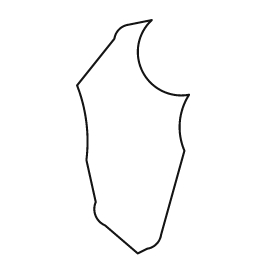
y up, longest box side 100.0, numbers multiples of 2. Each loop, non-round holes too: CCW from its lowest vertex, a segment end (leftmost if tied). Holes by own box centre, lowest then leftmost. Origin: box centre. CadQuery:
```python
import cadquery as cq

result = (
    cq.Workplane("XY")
    .moveTo(2.0, -50.0)
    .lineTo(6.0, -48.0)
    .threePointArc((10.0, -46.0), (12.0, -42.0))
    .lineTo(22.0, -6.0)
    .threePointArc((20.0, 6.0), (24.0, 18.0))
    .threePointArc((4.0, 28.0), (8.0, 50.0))
    .lineTo(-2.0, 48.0)
    .threePointArc((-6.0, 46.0), (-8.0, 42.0))
    .lineTo(-24.0, 22.0)
    .threePointArc((-20.0, 6.0), (-20.0, -10.0))
    .lineTo(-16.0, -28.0)
    .threePointArc((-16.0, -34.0), (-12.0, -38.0))
    .close()
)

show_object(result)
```